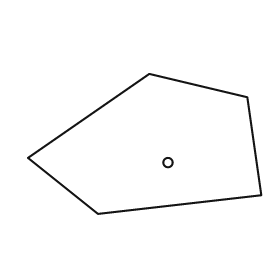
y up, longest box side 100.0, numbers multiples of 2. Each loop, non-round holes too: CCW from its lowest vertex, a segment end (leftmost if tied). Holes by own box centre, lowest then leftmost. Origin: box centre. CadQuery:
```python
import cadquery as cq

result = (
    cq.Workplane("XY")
    .moveTo(-20.0, -30.0)
    .lineTo(50.0, -22.0)
    .lineTo(44.0, 20.0)
    .lineTo(2.0, 30.0)
    .lineTo(-50.0, -6.0)
    .close()
    .moveTo(10.0, -8.0)
    .circle(2.0)
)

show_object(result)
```